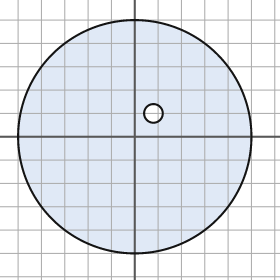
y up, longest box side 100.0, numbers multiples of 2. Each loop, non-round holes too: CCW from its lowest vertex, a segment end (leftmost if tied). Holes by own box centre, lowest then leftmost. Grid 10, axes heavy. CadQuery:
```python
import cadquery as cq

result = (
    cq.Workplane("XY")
    .moveTo(0.0, 0.0)
    .circle(50.0)
    .moveTo(8.0, 10.0)
    .circle(4.0)
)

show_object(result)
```